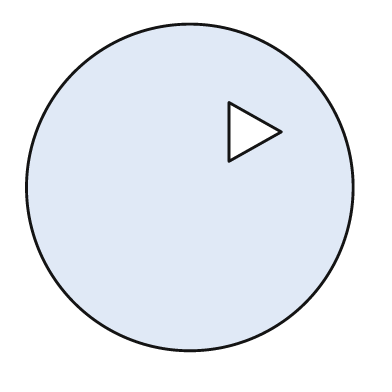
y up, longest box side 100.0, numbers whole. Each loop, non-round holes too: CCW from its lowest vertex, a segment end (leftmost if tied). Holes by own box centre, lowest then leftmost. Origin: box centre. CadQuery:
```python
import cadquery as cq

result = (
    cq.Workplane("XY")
    .moveTo(0.0, 0.0)
    .circle(50.0)
    .moveTo(12.0, 8.0)
    .lineTo(28.0, 17.0)
    .lineTo(12.0, 26.0)
    .close()
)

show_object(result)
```